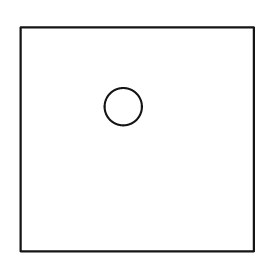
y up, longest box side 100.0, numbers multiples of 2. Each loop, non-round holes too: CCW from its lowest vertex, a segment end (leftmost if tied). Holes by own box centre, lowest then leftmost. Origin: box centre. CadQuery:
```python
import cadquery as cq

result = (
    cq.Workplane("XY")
    .moveTo(-50.0, -48.0)
    .lineTo(50.0, -48.0)
    .lineTo(50.0, 48.0)
    .lineTo(-50.0, 48.0)
    .close()
    .moveTo(-6.0, 14.0)
    .circle(8.0)
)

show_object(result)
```